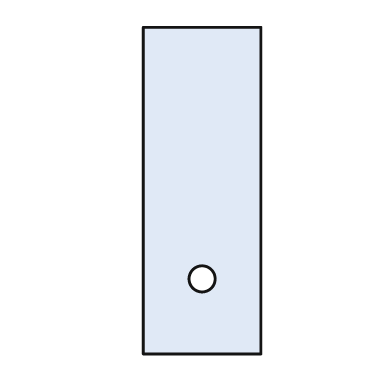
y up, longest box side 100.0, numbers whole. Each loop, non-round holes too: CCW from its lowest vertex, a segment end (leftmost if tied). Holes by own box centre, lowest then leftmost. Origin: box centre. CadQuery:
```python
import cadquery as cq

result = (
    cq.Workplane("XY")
    .moveTo(-18.0, -50.0)
    .lineTo(18.0, -50.0)
    .lineTo(18.0, 50.0)
    .lineTo(-18.0, 50.0)
    .close()
    .moveTo(0.0, -27.0)
    .circle(4.0)
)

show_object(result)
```